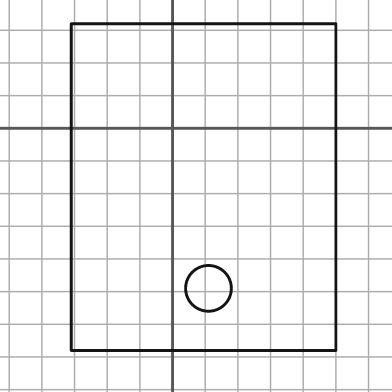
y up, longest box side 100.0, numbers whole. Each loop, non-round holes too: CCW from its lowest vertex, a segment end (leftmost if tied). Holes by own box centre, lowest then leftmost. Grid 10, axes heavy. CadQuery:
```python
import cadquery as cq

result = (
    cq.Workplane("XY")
    .moveTo(-31.0, -68.0)
    .lineTo(50.0, -68.0)
    .lineTo(50.0, 32.0)
    .lineTo(-31.0, 32.0)
    .close()
    .moveTo(11.0, -49.0)
    .circle(7.0)
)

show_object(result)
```